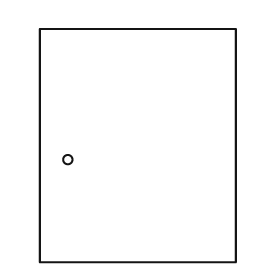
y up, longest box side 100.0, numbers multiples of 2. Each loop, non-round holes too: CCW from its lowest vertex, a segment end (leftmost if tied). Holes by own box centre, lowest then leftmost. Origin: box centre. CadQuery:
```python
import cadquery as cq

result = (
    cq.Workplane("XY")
    .moveTo(-42.0, -50.0)
    .lineTo(42.0, -50.0)
    .lineTo(42.0, 50.0)
    .lineTo(-42.0, 50.0)
    .close()
    .moveTo(-30.0, -6.0)
    .circle(2.0)
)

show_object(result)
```